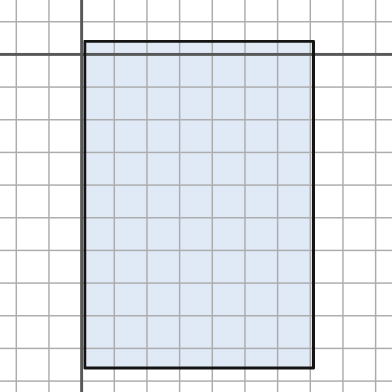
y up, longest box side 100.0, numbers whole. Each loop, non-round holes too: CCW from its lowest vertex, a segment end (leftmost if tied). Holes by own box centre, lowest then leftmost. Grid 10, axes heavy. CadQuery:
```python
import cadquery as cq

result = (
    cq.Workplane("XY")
    .moveTo(1.0, -96.0)
    .lineTo(71.0, -96.0)
    .lineTo(71.0, 4.0)
    .lineTo(1.0, 4.0)
    .close()
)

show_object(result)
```